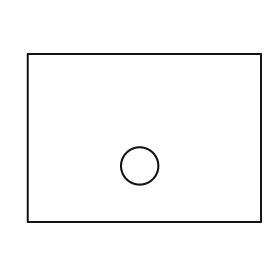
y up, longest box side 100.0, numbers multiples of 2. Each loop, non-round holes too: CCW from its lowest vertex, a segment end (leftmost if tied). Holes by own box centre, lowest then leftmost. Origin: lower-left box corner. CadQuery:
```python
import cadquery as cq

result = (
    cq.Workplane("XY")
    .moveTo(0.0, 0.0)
    .lineTo(100.0, 0.0)
    .lineTo(100.0, 72.0)
    .lineTo(0.0, 72.0)
    .close()
    .moveTo(48.0, 24.0)
    .circle(8.0)
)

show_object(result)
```